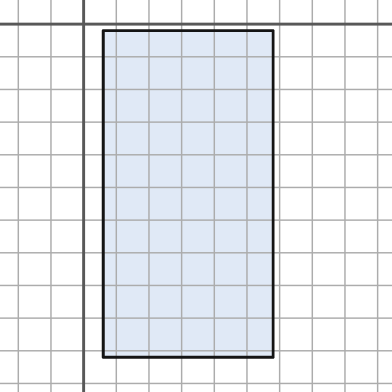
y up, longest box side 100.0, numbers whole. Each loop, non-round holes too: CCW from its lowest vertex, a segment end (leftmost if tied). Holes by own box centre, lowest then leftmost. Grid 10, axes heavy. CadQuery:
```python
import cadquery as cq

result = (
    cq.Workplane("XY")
    .moveTo(6.0, -102.0)
    .lineTo(58.0, -102.0)
    .lineTo(58.0, -2.0)
    .lineTo(6.0, -2.0)
    .close()
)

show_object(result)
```